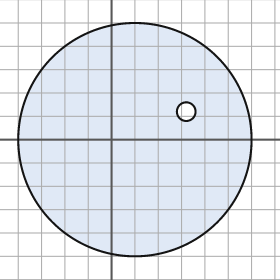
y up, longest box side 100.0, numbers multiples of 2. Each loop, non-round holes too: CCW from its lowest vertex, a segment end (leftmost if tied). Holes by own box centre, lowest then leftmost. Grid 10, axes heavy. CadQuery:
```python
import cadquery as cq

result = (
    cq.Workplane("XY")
    .moveTo(10.0, 0.0)
    .circle(50.0)
    .moveTo(32.0, 12.0)
    .circle(4.0)
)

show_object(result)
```